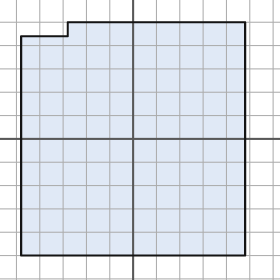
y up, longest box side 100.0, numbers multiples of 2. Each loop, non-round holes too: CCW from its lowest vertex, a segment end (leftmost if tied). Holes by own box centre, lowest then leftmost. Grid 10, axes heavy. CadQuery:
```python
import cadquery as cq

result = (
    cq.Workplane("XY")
    .moveTo(-48.0, -50.0)
    .lineTo(48.0, -50.0)
    .lineTo(48.0, 50.0)
    .lineTo(-28.0, 50.0)
    .lineTo(-28.0, 44.0)
    .lineTo(-48.0, 44.0)
    .close()
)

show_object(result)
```